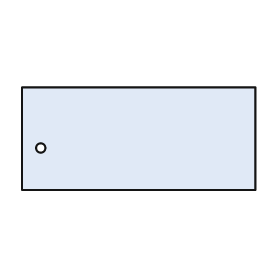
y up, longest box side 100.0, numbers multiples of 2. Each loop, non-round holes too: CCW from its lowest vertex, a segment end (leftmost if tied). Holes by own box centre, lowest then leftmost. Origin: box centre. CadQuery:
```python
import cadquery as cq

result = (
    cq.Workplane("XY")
    .moveTo(-50.0, -22.0)
    .lineTo(50.0, -22.0)
    .lineTo(50.0, 22.0)
    .lineTo(-50.0, 22.0)
    .close()
    .moveTo(-42.0, -4.0)
    .circle(2.0)
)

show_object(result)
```